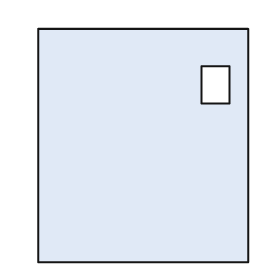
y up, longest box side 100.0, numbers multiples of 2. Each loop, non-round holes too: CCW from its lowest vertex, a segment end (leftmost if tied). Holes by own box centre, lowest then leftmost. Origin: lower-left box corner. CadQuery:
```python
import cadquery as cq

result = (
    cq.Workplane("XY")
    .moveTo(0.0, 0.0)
    .lineTo(90.0, 0.0)
    .lineTo(90.0, 100.0)
    .lineTo(0.0, 100.0)
    .close()
    .moveTo(70.0, 68.0)
    .lineTo(82.0, 68.0)
    .lineTo(82.0, 84.0)
    .lineTo(70.0, 84.0)
    .close()
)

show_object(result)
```